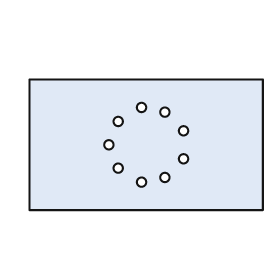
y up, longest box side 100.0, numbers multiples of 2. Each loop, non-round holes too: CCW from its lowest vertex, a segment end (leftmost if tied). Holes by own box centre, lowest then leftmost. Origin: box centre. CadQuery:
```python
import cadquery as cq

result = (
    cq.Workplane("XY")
    .moveTo(-50.0, -28.0)
    .lineTo(50.0, -28.0)
    .lineTo(50.0, 28.0)
    .lineTo(-50.0, 28.0)
    .close()
    .moveTo(-2.0, -16.0)
    .circle(2.0)
    .moveTo(8.0, -14.0)
    .circle(2.0)
    .moveTo(-12.0, -10.0)
    .circle(2.0)
    .moveTo(16.0, -6.0)
    .circle(2.0)
    .moveTo(-16.0, 0.0)
    .circle(2.0)
    .moveTo(16.0, 6.0)
    .circle(2.0)
    .moveTo(-12.0, 10.0)
    .circle(2.0)
    .moveTo(8.0, 14.0)
    .circle(2.0)
    .moveTo(-2.0, 16.0)
    .circle(2.0)
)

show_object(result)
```